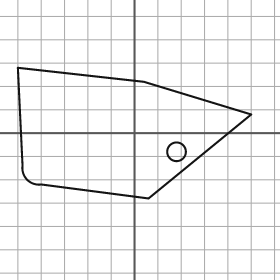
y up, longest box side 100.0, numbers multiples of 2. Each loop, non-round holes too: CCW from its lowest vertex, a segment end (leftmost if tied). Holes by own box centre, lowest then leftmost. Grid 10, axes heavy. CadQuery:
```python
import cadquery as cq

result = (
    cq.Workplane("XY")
    .moveTo(6.0, -28.0)
    .lineTo(50.0, 8.0)
    .lineTo(4.0, 22.0)
    .lineTo(-50.0, 28.0)
    .lineTo(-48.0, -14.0)
    .threePointArc((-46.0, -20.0), (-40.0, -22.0))
    .close()
    .moveTo(18.0, -8.0)
    .circle(4.0)
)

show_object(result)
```